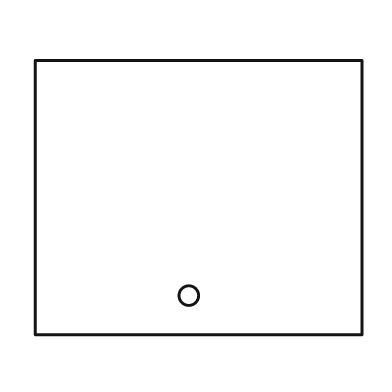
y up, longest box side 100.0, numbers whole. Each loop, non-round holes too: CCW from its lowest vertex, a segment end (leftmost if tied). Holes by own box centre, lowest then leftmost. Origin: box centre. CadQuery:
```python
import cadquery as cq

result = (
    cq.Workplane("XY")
    .moveTo(-50.0, -42.0)
    .lineTo(50.0, -42.0)
    .lineTo(50.0, 42.0)
    .lineTo(-50.0, 42.0)
    .close()
    .moveTo(-3.0, -30.0)
    .circle(3.0)
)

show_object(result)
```